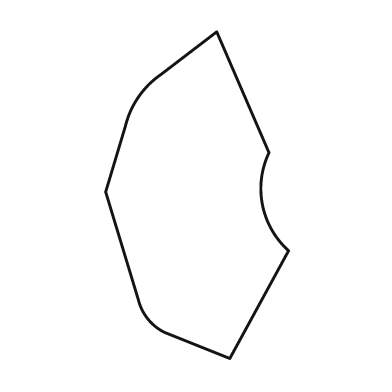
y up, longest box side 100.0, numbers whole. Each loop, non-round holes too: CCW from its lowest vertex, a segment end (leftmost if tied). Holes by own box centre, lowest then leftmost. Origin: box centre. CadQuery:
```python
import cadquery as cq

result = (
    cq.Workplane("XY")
    .moveTo(10.0, -50.0)
    .lineTo(28.0, -17.0)
    .threePointArc((20.0, -3.0), (22.0, 13.0))
    .lineTo(6.0, 50.0)
    .lineTo(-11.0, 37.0)
    .threePointArc((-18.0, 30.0), (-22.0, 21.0))
    .lineTo(-28.0, 1.0)
    .lineTo(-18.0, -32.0)
    .threePointArc((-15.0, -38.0), (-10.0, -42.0))
    .close()
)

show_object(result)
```